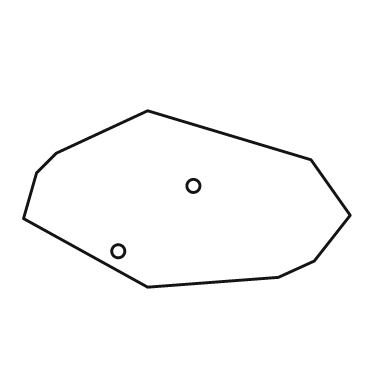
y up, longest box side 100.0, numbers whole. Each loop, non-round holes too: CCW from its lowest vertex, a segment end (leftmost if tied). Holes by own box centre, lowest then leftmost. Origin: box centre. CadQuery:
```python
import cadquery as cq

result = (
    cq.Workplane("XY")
    .moveTo(-12.0, -27.0)
    .lineTo(28.0, -24.0)
    .lineTo(39.0, -19.0)
    .lineTo(50.0, -5.0)
    .lineTo(38.0, 12.0)
    .lineTo(-12.0, 27.0)
    .lineTo(-40.0, 14.0)
    .lineTo(-46.0, 8.0)
    .lineTo(-50.0, -6.0)
    .close()
    .moveTo(-21.0, -16.0)
    .circle(2.0)
    .moveTo(2.0, 4.0)
    .circle(2.0)
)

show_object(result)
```